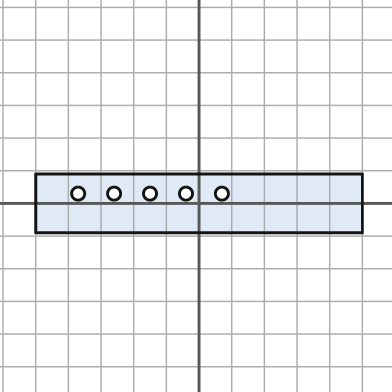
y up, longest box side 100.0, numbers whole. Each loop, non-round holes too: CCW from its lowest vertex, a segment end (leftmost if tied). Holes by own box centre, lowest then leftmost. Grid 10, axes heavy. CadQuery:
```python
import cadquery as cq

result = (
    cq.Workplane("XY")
    .moveTo(-50.0, -9.0)
    .lineTo(50.0, -9.0)
    .lineTo(50.0, 9.0)
    .lineTo(-50.0, 9.0)
    .close()
    .moveTo(-37.0, 3.0)
    .circle(2.0)
    .moveTo(-26.0, 3.0)
    .circle(2.0)
    .moveTo(-15.0, 3.0)
    .circle(2.0)
    .moveTo(-4.0, 3.0)
    .circle(2.0)
    .moveTo(7.0, 3.0)
    .circle(2.0)
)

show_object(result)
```